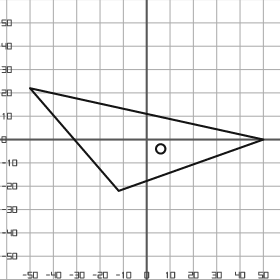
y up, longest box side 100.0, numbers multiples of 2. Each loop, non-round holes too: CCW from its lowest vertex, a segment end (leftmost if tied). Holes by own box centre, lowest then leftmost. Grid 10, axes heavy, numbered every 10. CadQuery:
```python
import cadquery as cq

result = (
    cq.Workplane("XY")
    .moveTo(-12.0, -22.0)
    .lineTo(50.0, 0.0)
    .lineTo(-50.0, 22.0)
    .close()
    .moveTo(6.0, -4.0)
    .circle(2.0)
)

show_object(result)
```